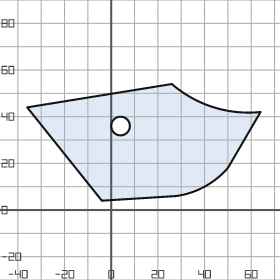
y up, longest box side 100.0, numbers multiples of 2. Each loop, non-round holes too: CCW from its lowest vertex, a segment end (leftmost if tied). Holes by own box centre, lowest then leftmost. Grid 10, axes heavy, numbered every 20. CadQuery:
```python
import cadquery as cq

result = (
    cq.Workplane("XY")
    .moveTo(-4.0, 4.0)
    .lineTo(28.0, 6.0)
    .threePointArc((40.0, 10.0), (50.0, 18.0))
    .lineTo(64.0, 42.0)
    .threePointArc((44.0, 44.0), (26.0, 54.0))
    .lineTo(-36.0, 44.0)
    .close()
    .moveTo(4.0, 36.0)
    .circle(4.0)
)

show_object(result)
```